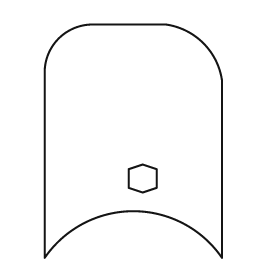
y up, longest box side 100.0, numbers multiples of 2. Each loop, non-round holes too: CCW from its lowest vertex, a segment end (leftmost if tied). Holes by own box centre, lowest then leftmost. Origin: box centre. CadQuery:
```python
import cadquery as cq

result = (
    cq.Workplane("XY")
    .moveTo(-38.0, -50.0)
    .threePointArc((0.0, -30.0), (38.0, -50.0))
    .lineTo(38.0, 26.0)
    .threePointArc((30.0, 42.0), (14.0, 50.0))
    .lineTo(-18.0, 50.0)
    .threePointArc((-32.0, 44.0), (-38.0, 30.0))
    .close()
    .moveTo(4.0, -22.0)
    .lineTo(10.0, -20.0)
    .lineTo(10.0, -12.0)
    .lineTo(4.0, -10.0)
    .lineTo(-2.0, -12.0)
    .lineTo(-2.0, -20.0)
    .close()
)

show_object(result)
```